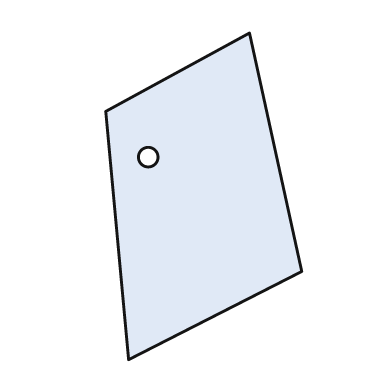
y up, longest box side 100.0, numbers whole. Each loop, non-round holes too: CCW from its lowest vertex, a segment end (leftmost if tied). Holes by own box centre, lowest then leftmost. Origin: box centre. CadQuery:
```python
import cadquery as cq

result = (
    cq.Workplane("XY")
    .moveTo(-23.0, -50.0)
    .lineTo(30.0, -23.0)
    .lineTo(14.0, 50.0)
    .lineTo(-30.0, 26.0)
    .close()
    .moveTo(-17.0, 12.0)
    .circle(3.0)
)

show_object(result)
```